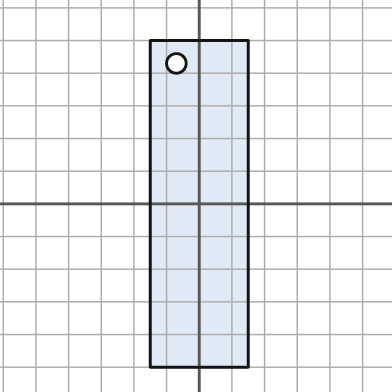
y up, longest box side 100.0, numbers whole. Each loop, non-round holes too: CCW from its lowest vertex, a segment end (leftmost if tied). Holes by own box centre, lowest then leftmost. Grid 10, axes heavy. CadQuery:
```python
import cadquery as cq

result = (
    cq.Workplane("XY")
    .moveTo(-15.0, -50.0)
    .lineTo(15.0, -50.0)
    .lineTo(15.0, 50.0)
    .lineTo(-15.0, 50.0)
    .close()
    .moveTo(-7.0, 43.0)
    .circle(3.0)
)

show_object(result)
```